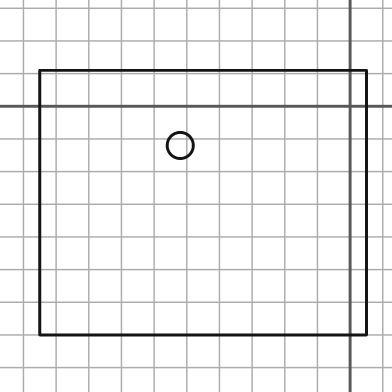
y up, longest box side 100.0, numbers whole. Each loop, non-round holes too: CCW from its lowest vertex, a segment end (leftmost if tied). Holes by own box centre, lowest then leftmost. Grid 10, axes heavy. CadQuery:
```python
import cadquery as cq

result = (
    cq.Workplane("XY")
    .moveTo(-95.0, -70.0)
    .lineTo(5.0, -70.0)
    .lineTo(5.0, 11.0)
    .lineTo(-95.0, 11.0)
    .close()
    .moveTo(-52.0, -12.0)
    .circle(4.0)
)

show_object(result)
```